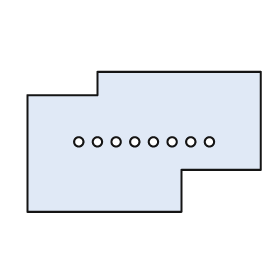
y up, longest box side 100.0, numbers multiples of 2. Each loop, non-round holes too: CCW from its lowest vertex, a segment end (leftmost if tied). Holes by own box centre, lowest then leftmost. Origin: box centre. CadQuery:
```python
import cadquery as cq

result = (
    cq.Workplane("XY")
    .moveTo(-50.0, -30.0)
    .lineTo(16.0, -30.0)
    .lineTo(16.0, -12.0)
    .lineTo(50.0, -12.0)
    .lineTo(50.0, 30.0)
    .lineTo(-20.0, 30.0)
    .lineTo(-20.0, 20.0)
    .lineTo(-50.0, 20.0)
    .close()
    .moveTo(-28.0, 0.0)
    .circle(2.0)
    .moveTo(-20.0, 0.0)
    .circle(2.0)
    .moveTo(-12.0, 0.0)
    .circle(2.0)
    .moveTo(-4.0, 0.0)
    .circle(2.0)
    .moveTo(4.0, 0.0)
    .circle(2.0)
    .moveTo(12.0, 0.0)
    .circle(2.0)
    .moveTo(20.0, 0.0)
    .circle(2.0)
    .moveTo(28.0, 0.0)
    .circle(2.0)
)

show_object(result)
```